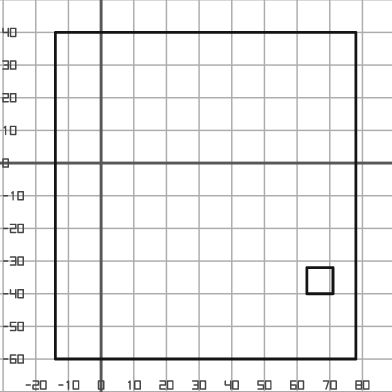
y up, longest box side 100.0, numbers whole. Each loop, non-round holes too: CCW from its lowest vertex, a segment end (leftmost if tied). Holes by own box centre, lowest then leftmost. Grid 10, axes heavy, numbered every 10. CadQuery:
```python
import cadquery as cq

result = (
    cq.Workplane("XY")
    .moveTo(-14.0, -60.0)
    .lineTo(78.0, -60.0)
    .lineTo(78.0, 40.0)
    .lineTo(-14.0, 40.0)
    .close()
    .moveTo(63.0, -40.0)
    .lineTo(71.0, -40.0)
    .lineTo(71.0, -32.0)
    .lineTo(63.0, -32.0)
    .close()
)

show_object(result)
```